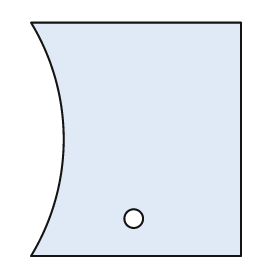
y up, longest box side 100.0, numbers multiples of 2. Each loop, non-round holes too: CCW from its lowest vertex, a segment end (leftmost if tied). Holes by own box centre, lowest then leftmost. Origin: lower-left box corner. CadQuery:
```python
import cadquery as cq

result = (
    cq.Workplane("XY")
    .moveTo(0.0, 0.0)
    .lineTo(90.0, 0.0)
    .lineTo(90.0, 100.0)
    .lineTo(0.0, 100.0)
    .threePointArc((14.0, 50.0), (0.0, 0.0))
    .close()
    .moveTo(44.0, 16.0)
    .circle(4.0)
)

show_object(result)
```